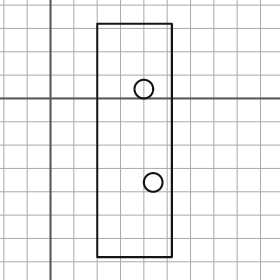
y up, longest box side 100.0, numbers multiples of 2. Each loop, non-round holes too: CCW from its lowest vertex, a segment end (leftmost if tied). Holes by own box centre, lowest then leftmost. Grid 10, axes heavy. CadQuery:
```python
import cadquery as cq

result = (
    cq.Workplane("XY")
    .moveTo(20.0, -68.0)
    .lineTo(52.0, -68.0)
    .lineTo(52.0, 32.0)
    .lineTo(20.0, 32.0)
    .close()
    .moveTo(44.0, -36.0)
    .circle(4.0)
    .moveTo(40.0, 4.0)
    .circle(4.0)
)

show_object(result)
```